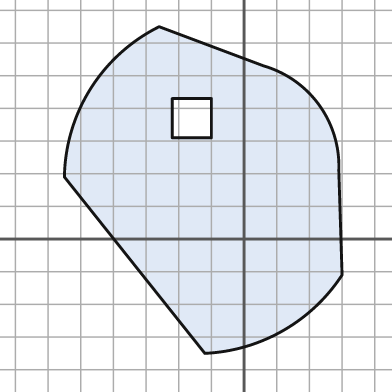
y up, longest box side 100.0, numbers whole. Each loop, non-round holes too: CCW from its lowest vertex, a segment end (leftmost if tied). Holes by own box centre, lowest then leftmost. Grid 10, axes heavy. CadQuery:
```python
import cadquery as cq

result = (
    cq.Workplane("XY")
    .moveTo(-12.0, -35.0)
    .threePointArc((12.0, -28.0), (30.0, -11.0))
    .lineTo(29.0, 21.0)
    .threePointArc((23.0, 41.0), (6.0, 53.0))
    .lineTo(-26.0, 65.0)
    .threePointArc((-47.0, 46.0), (-55.0, 19.0))
    .close()
    .moveTo(-22.0, 31.0)
    .lineTo(-10.0, 31.0)
    .lineTo(-10.0, 43.0)
    .lineTo(-22.0, 43.0)
    .close()
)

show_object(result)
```